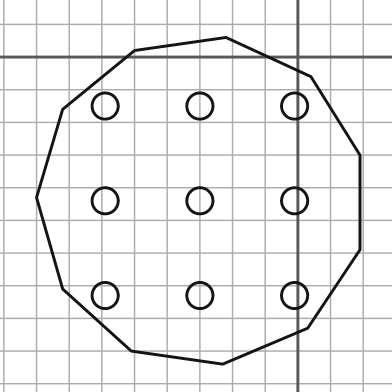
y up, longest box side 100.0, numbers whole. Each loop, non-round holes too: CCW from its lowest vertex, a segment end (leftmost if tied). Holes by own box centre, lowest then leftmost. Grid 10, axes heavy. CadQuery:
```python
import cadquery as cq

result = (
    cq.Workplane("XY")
    .moveTo(-23.0, -94.0)
    .lineTo(3.0, -83.0)
    .lineTo(19.0, -59.0)
    .lineTo(19.0, -30.0)
    .lineTo(4.0, -6.0)
    .lineTo(-22.0, 6.0)
    .lineTo(-50.0, 2.0)
    .lineTo(-72.0, -16.0)
    .lineTo(-80.0, -43.0)
    .lineTo(-72.0, -71.0)
    .lineTo(-51.0, -90.0)
    .close()
    .moveTo(-59.0, -73.0)
    .circle(4.0)
    .moveTo(-30.0, -73.0)
    .circle(4.0)
    .moveTo(-1.0, -73.0)
    .circle(4.0)
    .moveTo(-59.0, -44.0)
    .circle(4.0)
    .moveTo(-30.0, -44.0)
    .circle(4.0)
    .moveTo(-1.0, -44.0)
    .circle(4.0)
    .moveTo(-59.0, -15.0)
    .circle(4.0)
    .moveTo(-30.0, -15.0)
    .circle(4.0)
    .moveTo(-1.0, -15.0)
    .circle(4.0)
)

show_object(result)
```